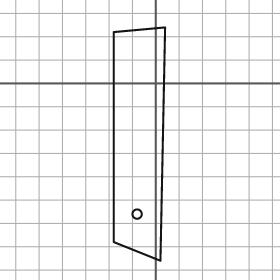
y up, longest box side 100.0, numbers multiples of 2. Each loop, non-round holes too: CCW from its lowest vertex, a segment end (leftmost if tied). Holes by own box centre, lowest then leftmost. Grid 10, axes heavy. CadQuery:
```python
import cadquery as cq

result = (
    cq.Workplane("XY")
    .moveTo(2.0, -76.0)
    .lineTo(4.0, 24.0)
    .lineTo(-18.0, 22.0)
    .lineTo(-18.0, -68.0)
    .close()
    .moveTo(-8.0, -56.0)
    .circle(2.0)
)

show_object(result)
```